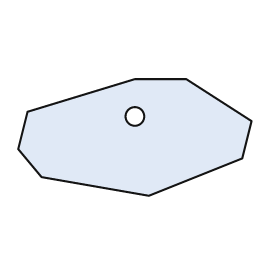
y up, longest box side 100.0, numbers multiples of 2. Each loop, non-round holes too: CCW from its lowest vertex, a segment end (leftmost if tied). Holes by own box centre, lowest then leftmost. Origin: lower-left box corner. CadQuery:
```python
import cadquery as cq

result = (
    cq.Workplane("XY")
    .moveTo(56.0, 0.0)
    .lineTo(96.0, 16.0)
    .lineTo(100.0, 32.0)
    .lineTo(72.0, 50.0)
    .lineTo(50.0, 50.0)
    .lineTo(4.0, 36.0)
    .lineTo(0.0, 20.0)
    .lineTo(10.0, 8.0)
    .close()
    .moveTo(50.0, 34.0)
    .circle(4.0)
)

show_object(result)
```